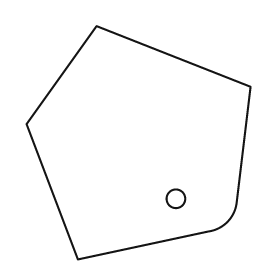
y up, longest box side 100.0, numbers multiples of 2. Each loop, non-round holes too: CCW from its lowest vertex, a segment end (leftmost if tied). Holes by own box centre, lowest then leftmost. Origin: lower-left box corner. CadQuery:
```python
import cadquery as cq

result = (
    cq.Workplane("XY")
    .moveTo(22.0, 0.0)
    .lineTo(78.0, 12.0)
    .threePointArc((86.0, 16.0), (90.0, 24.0))
    .lineTo(96.0, 74.0)
    .lineTo(30.0, 100.0)
    .lineTo(0.0, 58.0)
    .close()
    .moveTo(64.0, 26.0)
    .circle(4.0)
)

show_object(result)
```